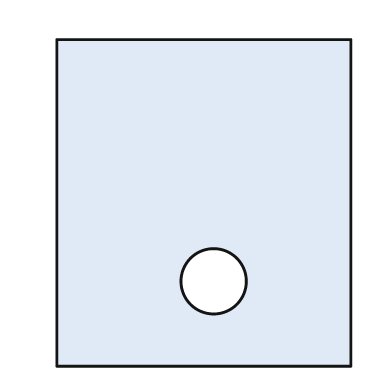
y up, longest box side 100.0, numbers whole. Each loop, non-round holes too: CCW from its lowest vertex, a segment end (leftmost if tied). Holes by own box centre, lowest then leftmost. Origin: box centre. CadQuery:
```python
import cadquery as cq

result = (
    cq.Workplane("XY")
    .moveTo(-45.0, -50.0)
    .lineTo(45.0, -50.0)
    .lineTo(45.0, 50.0)
    .lineTo(-45.0, 50.0)
    .close()
    .moveTo(3.0, -24.0)
    .circle(10.0)
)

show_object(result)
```